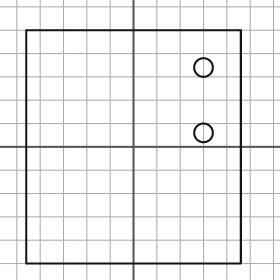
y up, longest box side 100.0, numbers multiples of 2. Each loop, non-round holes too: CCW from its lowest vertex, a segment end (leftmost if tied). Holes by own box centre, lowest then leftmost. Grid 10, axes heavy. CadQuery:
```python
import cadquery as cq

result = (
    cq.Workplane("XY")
    .moveTo(-46.0, -50.0)
    .lineTo(46.0, -50.0)
    .lineTo(46.0, 50.0)
    .lineTo(-46.0, 50.0)
    .close()
    .moveTo(30.0, 6.0)
    .circle(4.0)
    .moveTo(30.0, 34.0)
    .circle(4.0)
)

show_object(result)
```